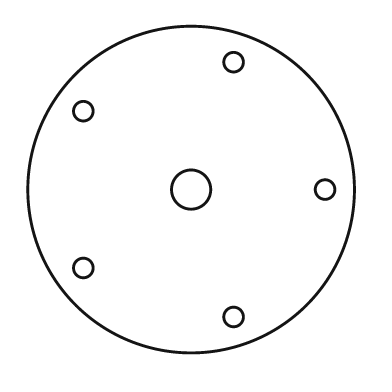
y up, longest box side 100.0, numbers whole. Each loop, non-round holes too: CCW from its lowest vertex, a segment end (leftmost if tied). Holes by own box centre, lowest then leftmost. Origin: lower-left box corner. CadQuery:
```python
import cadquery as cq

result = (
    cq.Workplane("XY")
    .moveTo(50.0, 50.0)
    .circle(50.0)
    .moveTo(63.0, 11.0)
    .circle(3.0)
    .moveTo(17.0, 26.0)
    .circle(3.0)
    .moveTo(50.0, 50.0)
    .circle(6.0)
    .moveTo(91.0, 50.0)
    .circle(3.0)
    .moveTo(17.0, 74.0)
    .circle(3.0)
    .moveTo(63.0, 89.0)
    .circle(3.0)
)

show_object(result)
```